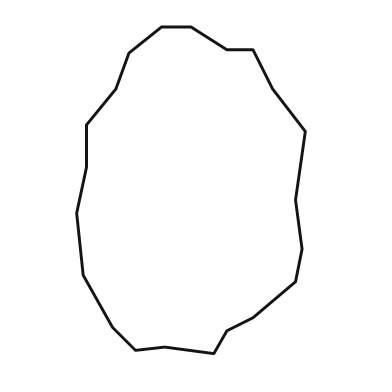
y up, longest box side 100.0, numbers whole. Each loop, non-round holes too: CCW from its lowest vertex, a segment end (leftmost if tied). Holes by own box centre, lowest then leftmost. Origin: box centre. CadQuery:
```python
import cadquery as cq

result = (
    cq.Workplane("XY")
    .moveTo(7.0, -50.0)
    .lineTo(11.0, -43.0)
    .lineTo(19.0, -39.0)
    .lineTo(32.0, -28.0)
    .lineTo(34.0, -18.0)
    .lineTo(32.0, -3.0)
    .lineTo(35.0, 18.0)
    .lineTo(25.0, 31.0)
    .lineTo(19.0, 43.0)
    .lineTo(11.0, 43.0)
    .lineTo(0.0, 50.0)
    .lineTo(-9.0, 50.0)
    .lineTo(-19.0, 42.0)
    .lineTo(-23.0, 31.0)
    .lineTo(-32.0, 20.0)
    .lineTo(-32.0, 7.0)
    .lineTo(-35.0, -7.0)
    .lineTo(-33.0, -26.0)
    .lineTo(-24.0, -42.0)
    .lineTo(-17.0, -49.0)
    .lineTo(-8.0, -48.0)
    .close()
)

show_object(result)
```